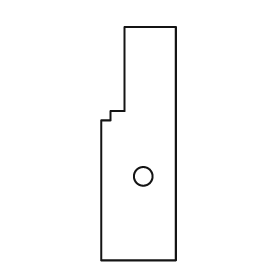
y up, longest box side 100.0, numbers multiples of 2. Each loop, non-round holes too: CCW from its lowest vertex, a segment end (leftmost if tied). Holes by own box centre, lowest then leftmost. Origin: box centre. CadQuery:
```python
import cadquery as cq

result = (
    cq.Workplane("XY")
    .moveTo(-16.0, -50.0)
    .lineTo(16.0, -50.0)
    .lineTo(16.0, 50.0)
    .lineTo(-6.0, 50.0)
    .lineTo(-6.0, 14.0)
    .lineTo(-12.0, 14.0)
    .lineTo(-12.0, 10.0)
    .lineTo(-16.0, 10.0)
    .close()
    .moveTo(2.0, -14.0)
    .circle(4.0)
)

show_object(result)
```